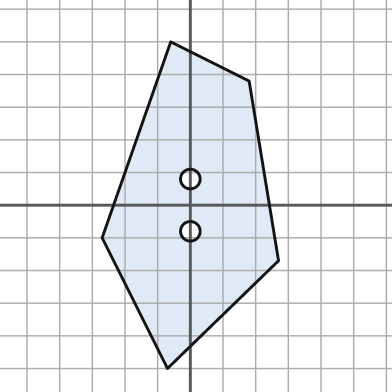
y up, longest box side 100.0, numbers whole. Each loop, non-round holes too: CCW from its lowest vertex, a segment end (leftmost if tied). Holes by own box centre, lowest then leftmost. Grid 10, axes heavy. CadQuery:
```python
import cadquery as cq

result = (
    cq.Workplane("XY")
    .moveTo(-7.0, -50.0)
    .lineTo(27.0, -17.0)
    .lineTo(18.0, 38.0)
    .lineTo(-6.0, 50.0)
    .lineTo(-27.0, -10.0)
    .close()
    .moveTo(0.0, -8.0)
    .circle(3.0)
    .moveTo(0.0, 8.0)
    .circle(3.0)
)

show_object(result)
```